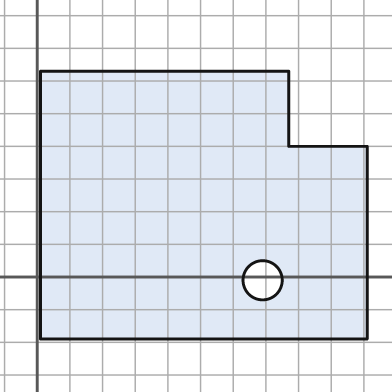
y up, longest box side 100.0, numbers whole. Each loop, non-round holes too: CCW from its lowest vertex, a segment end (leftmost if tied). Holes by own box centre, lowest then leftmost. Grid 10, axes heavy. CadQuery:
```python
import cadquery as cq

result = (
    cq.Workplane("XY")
    .moveTo(1.0, -19.0)
    .lineTo(101.0, -19.0)
    .lineTo(101.0, 40.0)
    .lineTo(77.0, 40.0)
    .lineTo(77.0, 63.0)
    .lineTo(1.0, 63.0)
    .close()
    .moveTo(69.0, -1.0)
    .circle(6.0)
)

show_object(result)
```